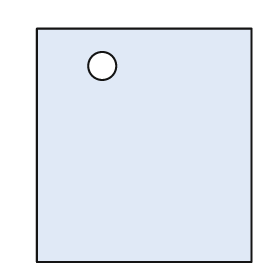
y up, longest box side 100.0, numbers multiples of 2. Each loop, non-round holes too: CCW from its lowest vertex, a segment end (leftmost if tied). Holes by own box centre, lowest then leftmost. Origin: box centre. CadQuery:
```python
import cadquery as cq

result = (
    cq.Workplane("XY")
    .moveTo(-46.0, -50.0)
    .lineTo(46.0, -50.0)
    .lineTo(46.0, 50.0)
    .lineTo(-46.0, 50.0)
    .close()
    .moveTo(-18.0, 34.0)
    .circle(6.0)
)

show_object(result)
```